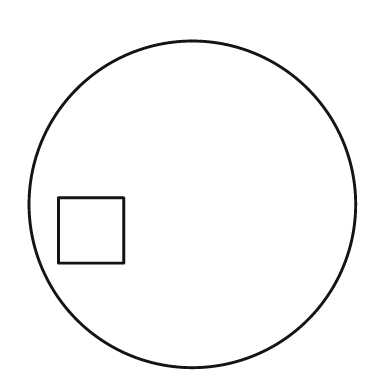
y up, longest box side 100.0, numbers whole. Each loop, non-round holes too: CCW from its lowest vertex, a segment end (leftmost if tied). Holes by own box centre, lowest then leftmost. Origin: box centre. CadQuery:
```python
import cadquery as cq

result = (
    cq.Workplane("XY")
    .moveTo(0.0, 0.0)
    .circle(50.0)
    .moveTo(-41.0, -18.0)
    .lineTo(-21.0, -18.0)
    .lineTo(-21.0, 2.0)
    .lineTo(-41.0, 2.0)
    .close()
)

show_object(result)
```